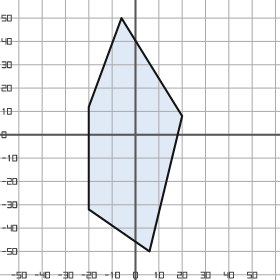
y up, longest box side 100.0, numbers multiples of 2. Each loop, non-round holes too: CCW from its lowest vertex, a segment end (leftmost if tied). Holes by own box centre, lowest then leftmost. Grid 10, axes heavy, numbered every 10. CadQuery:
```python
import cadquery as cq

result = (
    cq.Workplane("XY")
    .moveTo(6.0, -50.0)
    .lineTo(20.0, 8.0)
    .lineTo(-6.0, 50.0)
    .lineTo(-20.0, 12.0)
    .lineTo(-20.0, -32.0)
    .close()
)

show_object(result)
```